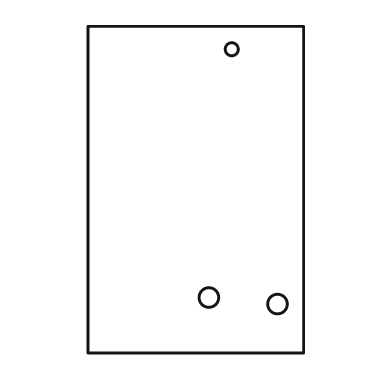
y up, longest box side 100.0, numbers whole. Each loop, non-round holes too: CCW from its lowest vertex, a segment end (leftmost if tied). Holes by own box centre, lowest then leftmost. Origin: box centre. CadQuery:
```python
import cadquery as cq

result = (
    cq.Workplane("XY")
    .moveTo(-33.0, -50.0)
    .lineTo(33.0, -50.0)
    .lineTo(33.0, 50.0)
    .lineTo(-33.0, 50.0)
    .close()
    .moveTo(25.0, -35.0)
    .circle(3.0)
    .moveTo(4.0, -33.0)
    .circle(3.0)
    .moveTo(11.0, 43.0)
    .circle(2.0)
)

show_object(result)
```